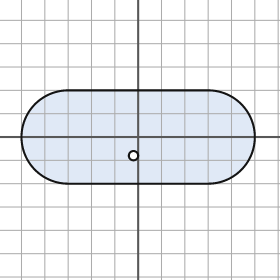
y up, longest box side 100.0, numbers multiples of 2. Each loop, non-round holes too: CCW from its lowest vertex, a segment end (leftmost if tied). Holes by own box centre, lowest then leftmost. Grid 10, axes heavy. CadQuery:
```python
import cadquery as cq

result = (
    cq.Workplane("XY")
    .moveTo(-30.0, -20.0)
    .lineTo(30.0, -20.0)
    .threePointArc((50.0, 0.0), (30.0, 20.0))
    .lineTo(-30.0, 20.0)
    .threePointArc((-50.0, 0.0), (-30.0, -20.0))
    .close()
    .moveTo(-2.0, -8.0)
    .circle(2.0)
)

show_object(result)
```